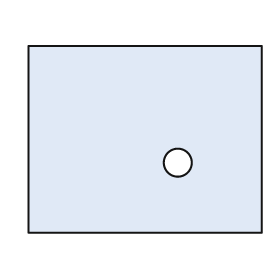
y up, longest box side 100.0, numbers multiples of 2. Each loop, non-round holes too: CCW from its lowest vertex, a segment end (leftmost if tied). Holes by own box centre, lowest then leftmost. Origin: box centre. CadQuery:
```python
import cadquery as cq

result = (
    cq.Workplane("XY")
    .moveTo(-50.0, -40.0)
    .lineTo(50.0, -40.0)
    .lineTo(50.0, 40.0)
    .lineTo(-50.0, 40.0)
    .close()
    .moveTo(14.0, -10.0)
    .circle(6.0)
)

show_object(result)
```